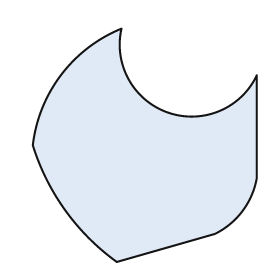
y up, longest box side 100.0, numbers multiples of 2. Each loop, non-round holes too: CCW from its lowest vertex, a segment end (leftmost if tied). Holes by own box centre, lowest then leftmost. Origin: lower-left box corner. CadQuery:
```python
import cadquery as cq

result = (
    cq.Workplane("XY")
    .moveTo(36.0, 0.0)
    .lineTo(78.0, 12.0)
    .threePointArc((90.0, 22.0), (96.0, 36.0))
    .lineTo(96.0, 80.0)
    .threePointArc((58.0, 64.0), (38.0, 100.0))
    .threePointArc((12.0, 80.0), (0.0, 50.0))
    .threePointArc((14.0, 22.0), (36.0, 0.0))
    .close()
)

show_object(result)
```